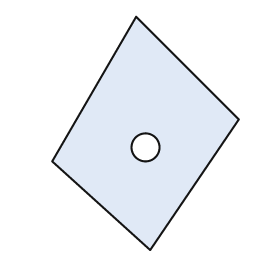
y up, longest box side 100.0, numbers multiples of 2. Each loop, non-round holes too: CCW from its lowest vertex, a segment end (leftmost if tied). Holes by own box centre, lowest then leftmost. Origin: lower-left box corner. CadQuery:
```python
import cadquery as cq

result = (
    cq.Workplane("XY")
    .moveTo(42.0, 0.0)
    .lineTo(80.0, 56.0)
    .lineTo(36.0, 100.0)
    .lineTo(0.0, 38.0)
    .close()
    .moveTo(40.0, 44.0)
    .circle(6.0)
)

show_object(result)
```